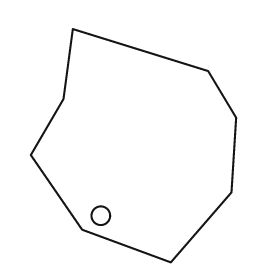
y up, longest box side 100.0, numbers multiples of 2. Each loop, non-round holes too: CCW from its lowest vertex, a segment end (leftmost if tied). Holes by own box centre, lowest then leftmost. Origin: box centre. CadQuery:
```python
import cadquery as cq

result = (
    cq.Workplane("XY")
    .moveTo(16.0, -50.0)
    .lineTo(42.0, -20.0)
    .lineTo(44.0, 12.0)
    .lineTo(32.0, 32.0)
    .lineTo(-26.0, 50.0)
    .lineTo(-30.0, 20.0)
    .lineTo(-44.0, -4.0)
    .lineTo(-22.0, -36.0)
    .close()
    .moveTo(-14.0, -30.0)
    .circle(4.0)
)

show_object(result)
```